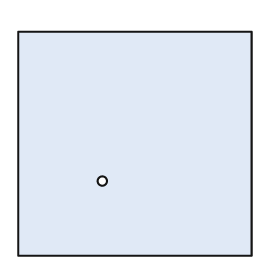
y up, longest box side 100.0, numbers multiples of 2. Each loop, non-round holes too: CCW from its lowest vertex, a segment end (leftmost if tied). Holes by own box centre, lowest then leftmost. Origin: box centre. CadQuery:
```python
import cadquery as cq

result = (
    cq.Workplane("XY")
    .moveTo(-50.0, -48.0)
    .lineTo(50.0, -48.0)
    .lineTo(50.0, 48.0)
    .lineTo(-50.0, 48.0)
    .close()
    .moveTo(-14.0, -16.0)
    .circle(2.0)
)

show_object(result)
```